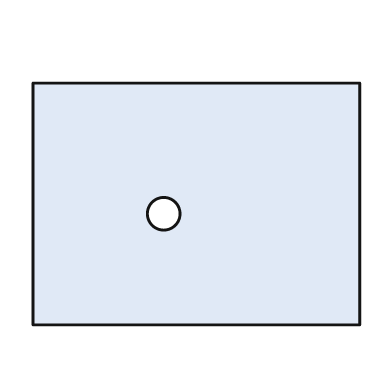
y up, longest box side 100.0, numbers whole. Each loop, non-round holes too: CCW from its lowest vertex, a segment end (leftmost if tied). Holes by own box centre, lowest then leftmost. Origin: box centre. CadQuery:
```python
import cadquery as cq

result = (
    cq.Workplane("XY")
    .moveTo(-50.0, -37.0)
    .lineTo(50.0, -37.0)
    .lineTo(50.0, 37.0)
    .lineTo(-50.0, 37.0)
    .close()
    .moveTo(-10.0, -3.0)
    .circle(5.0)
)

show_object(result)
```